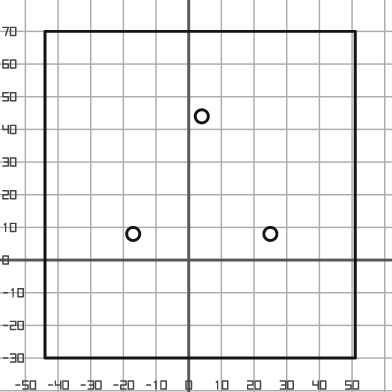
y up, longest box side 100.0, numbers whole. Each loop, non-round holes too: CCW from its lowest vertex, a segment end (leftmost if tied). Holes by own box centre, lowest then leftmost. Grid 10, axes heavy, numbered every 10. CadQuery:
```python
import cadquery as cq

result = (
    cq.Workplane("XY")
    .moveTo(-44.0, -30.0)
    .lineTo(51.0, -30.0)
    .lineTo(51.0, 70.0)
    .lineTo(-44.0, 70.0)
    .close()
    .moveTo(-17.0, 8.0)
    .circle(2.0)
    .moveTo(25.0, 8.0)
    .circle(2.0)
    .moveTo(4.0, 44.0)
    .circle(2.0)
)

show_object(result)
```